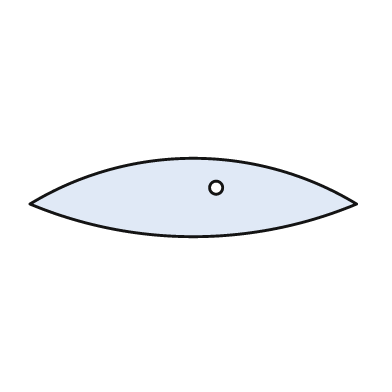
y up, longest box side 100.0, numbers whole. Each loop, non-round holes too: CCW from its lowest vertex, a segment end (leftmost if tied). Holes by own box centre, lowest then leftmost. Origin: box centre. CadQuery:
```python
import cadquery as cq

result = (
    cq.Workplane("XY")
    .moveTo(-50.0, -2.0)
    .threePointArc((0.0, -12.0), (50.0, -2.0))
    .threePointArc((0.0, 12.0), (-50.0, -2.0))
    .close()
    .moveTo(7.0, 3.0)
    .circle(2.0)
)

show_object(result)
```